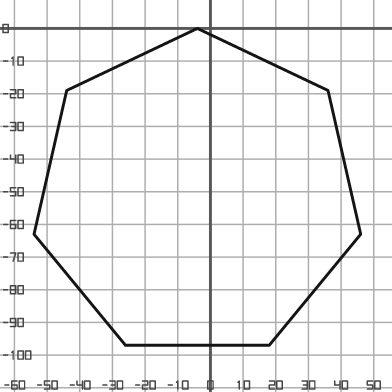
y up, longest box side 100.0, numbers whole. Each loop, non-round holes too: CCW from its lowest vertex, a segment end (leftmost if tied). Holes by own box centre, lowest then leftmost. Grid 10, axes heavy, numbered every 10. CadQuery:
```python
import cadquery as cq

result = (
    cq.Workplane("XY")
    .moveTo(-26.0, -97.0)
    .lineTo(18.0, -97.0)
    .lineTo(46.0, -63.0)
    .lineTo(36.0, -19.0)
    .lineTo(-4.0, 0.0)
    .lineTo(-44.0, -19.0)
    .lineTo(-54.0, -63.0)
    .close()
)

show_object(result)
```